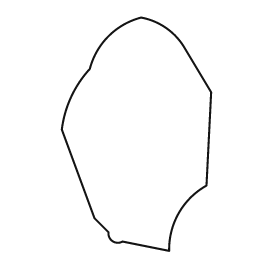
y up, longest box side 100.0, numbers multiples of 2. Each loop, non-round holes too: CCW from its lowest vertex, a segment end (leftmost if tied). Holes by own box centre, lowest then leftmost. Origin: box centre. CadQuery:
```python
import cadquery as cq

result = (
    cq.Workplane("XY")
    .moveTo(14.0, -50.0)
    .threePointArc((18.0, -34.0), (30.0, -22.0))
    .lineTo(32.0, 18.0)
    .lineTo(20.0, 38.0)
    .threePointArc((12.0, 46.0), (2.0, 50.0))
    .threePointArc((-12.0, 42.0), (-20.0, 28.0))
    .threePointArc((-28.0, 16.0), (-32.0, 2.0))
    .lineTo(-18.0, -36.0)
    .lineTo(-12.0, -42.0)
    .threePointArc((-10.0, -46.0), (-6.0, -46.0))
    .close()
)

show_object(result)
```